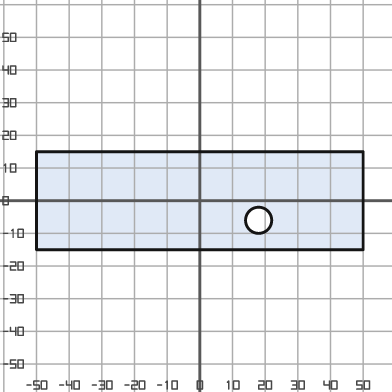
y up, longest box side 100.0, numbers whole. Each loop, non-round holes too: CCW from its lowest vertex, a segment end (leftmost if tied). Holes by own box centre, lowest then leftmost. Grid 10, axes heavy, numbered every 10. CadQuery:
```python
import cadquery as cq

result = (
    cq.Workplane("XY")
    .moveTo(-50.0, -15.0)
    .lineTo(50.0, -15.0)
    .lineTo(50.0, 15.0)
    .lineTo(-50.0, 15.0)
    .close()
    .moveTo(18.0, -6.0)
    .circle(4.0)
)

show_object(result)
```